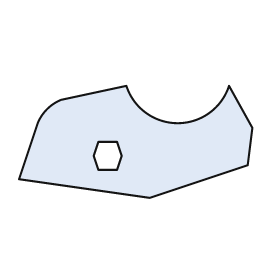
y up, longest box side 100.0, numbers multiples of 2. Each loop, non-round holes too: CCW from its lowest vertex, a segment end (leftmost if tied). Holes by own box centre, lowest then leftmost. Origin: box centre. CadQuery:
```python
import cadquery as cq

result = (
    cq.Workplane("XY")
    .moveTo(6.0, -24.0)
    .lineTo(48.0, -10.0)
    .lineTo(50.0, 6.0)
    .lineTo(40.0, 24.0)
    .threePointArc((18.0, 8.0), (-4.0, 24.0))
    .lineTo(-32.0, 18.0)
    .threePointArc((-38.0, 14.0), (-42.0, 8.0))
    .lineTo(-50.0, -16.0)
    .close()
    .moveTo(-16.0, -12.0)
    .lineTo(-8.0, -12.0)
    .lineTo(-6.0, -6.0)
    .lineTo(-8.0, 0.0)
    .lineTo(-16.0, 0.0)
    .lineTo(-18.0, -6.0)
    .close()
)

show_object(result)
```